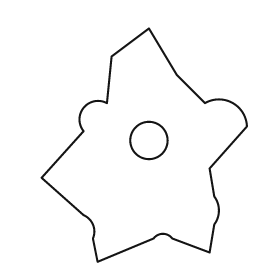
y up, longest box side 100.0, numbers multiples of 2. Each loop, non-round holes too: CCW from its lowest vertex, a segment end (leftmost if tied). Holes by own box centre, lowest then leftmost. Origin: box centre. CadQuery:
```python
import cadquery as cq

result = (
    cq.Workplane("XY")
    .moveTo(-20.0, -50.0)
    .lineTo(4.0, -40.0)
    .threePointArc((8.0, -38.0), (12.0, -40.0))
    .lineTo(28.0, -46.0)
    .lineTo(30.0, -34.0)
    .threePointArc((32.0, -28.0), (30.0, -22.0))
    .lineTo(28.0, -10.0)
    .lineTo(44.0, 8.0)
    .threePointArc((38.0, 18.0), (26.0, 18.0))
    .lineTo(14.0, 30.0)
    .lineTo(2.0, 50.0)
    .lineTo(-14.0, 38.0)
    .lineTo(-16.0, 18.0)
    .threePointArc((-26.0, 16.0), (-26.0, 6.0))
    .lineTo(-44.0, -14.0)
    .lineTo(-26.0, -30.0)
    .threePointArc((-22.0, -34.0), (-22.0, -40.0))
    .close()
    .moveTo(2.0, 2.0)
    .circle(8.0)
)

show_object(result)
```